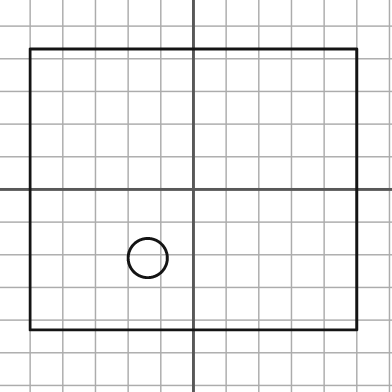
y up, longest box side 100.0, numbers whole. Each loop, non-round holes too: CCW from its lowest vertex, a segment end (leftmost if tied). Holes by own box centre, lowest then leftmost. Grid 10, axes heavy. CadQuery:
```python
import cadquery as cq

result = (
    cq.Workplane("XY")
    .moveTo(-50.0, -43.0)
    .lineTo(50.0, -43.0)
    .lineTo(50.0, 43.0)
    .lineTo(-50.0, 43.0)
    .close()
    .moveTo(-14.0, -21.0)
    .circle(6.0)
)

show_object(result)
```